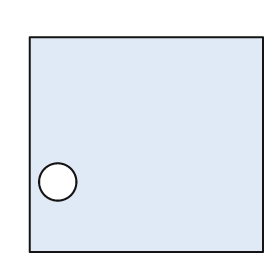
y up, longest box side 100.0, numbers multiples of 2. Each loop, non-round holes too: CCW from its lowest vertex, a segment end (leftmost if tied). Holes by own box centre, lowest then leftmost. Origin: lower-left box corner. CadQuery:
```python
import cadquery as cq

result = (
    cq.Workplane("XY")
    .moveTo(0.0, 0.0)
    .lineTo(100.0, 0.0)
    .lineTo(100.0, 92.0)
    .lineTo(0.0, 92.0)
    .close()
    .moveTo(12.0, 30.0)
    .circle(8.0)
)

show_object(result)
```